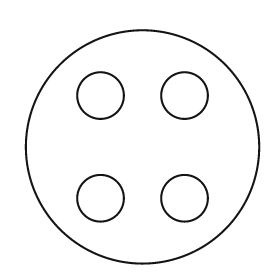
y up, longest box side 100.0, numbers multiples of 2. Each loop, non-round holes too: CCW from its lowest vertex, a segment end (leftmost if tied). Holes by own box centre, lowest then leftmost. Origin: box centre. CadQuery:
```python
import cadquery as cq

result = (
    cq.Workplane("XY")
    .moveTo(0.0, 0.0)
    .circle(50.0)
    .moveTo(-18.0, -22.0)
    .circle(10.0)
    .moveTo(18.0, -22.0)
    .circle(10.0)
    .moveTo(-18.0, 22.0)
    .circle(10.0)
    .moveTo(18.0, 22.0)
    .circle(10.0)
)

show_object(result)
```